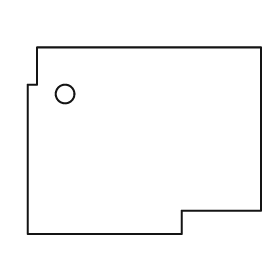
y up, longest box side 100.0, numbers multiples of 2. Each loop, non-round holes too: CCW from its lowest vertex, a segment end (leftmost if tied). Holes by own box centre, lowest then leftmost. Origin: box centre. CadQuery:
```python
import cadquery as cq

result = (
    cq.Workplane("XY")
    .moveTo(-50.0, -40.0)
    .lineTo(16.0, -40.0)
    .lineTo(16.0, -30.0)
    .lineTo(50.0, -30.0)
    .lineTo(50.0, 40.0)
    .lineTo(-46.0, 40.0)
    .lineTo(-46.0, 24.0)
    .lineTo(-50.0, 24.0)
    .close()
    .moveTo(-34.0, 20.0)
    .circle(4.0)
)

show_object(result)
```